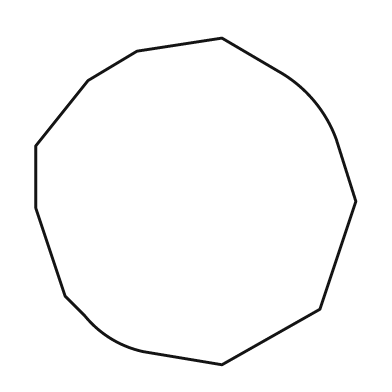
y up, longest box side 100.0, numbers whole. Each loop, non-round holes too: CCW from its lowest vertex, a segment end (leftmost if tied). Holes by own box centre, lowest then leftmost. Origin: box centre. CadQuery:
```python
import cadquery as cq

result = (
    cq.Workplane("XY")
    .moveTo(8.0, -50.0)
    .lineTo(38.0, -33.0)
    .lineTo(49.0, 0.0)
    .lineTo(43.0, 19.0)
    .threePointArc((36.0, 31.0), (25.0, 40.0))
    .lineTo(8.0, 50.0)
    .lineTo(-18.0, 46.0)
    .lineTo(-33.0, 37.0)
    .lineTo(-49.0, 17.0)
    .lineTo(-49.0, -2.0)
    .lineTo(-40.0, -29.0)
    .lineTo(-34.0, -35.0)
    .threePointArc((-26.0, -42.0), (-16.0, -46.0))
    .close()
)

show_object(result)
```